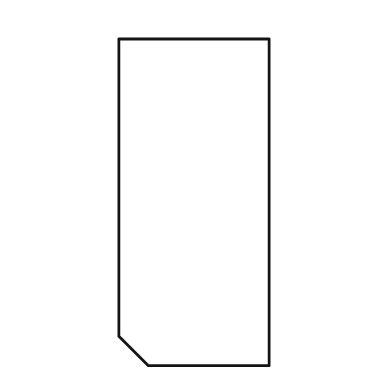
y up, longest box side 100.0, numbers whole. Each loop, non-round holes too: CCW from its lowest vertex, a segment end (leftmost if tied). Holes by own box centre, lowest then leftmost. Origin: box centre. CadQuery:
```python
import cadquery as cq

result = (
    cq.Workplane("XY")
    .moveTo(-14.0, -50.0)
    .lineTo(23.0, -50.0)
    .lineTo(23.0, 50.0)
    .lineTo(-23.0, 50.0)
    .lineTo(-23.0, -41.0)
    .close()
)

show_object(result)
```